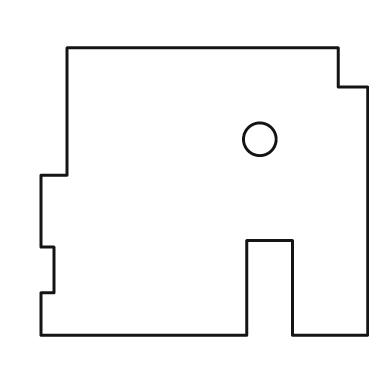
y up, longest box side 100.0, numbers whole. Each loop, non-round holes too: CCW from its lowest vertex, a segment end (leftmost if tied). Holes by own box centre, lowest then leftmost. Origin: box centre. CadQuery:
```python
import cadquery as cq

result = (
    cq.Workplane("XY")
    .moveTo(-50.0, -44.0)
    .lineTo(13.0, -44.0)
    .lineTo(13.0, -15.0)
    .lineTo(27.0, -15.0)
    .lineTo(27.0, -44.0)
    .lineTo(50.0, -44.0)
    .lineTo(50.0, 32.0)
    .lineTo(41.0, 32.0)
    .lineTo(41.0, 44.0)
    .lineTo(-42.0, 44.0)
    .lineTo(-42.0, 5.0)
    .lineTo(-50.0, 5.0)
    .lineTo(-50.0, -17.0)
    .lineTo(-46.0, -17.0)
    .lineTo(-46.0, -31.0)
    .lineTo(-50.0, -31.0)
    .close()
    .moveTo(17.0, 16.0)
    .circle(5.0)
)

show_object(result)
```